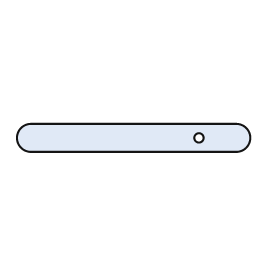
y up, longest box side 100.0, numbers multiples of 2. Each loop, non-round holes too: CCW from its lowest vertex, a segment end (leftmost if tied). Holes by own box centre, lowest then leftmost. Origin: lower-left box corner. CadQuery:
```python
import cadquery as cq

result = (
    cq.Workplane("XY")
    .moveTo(6.0, 0.0)
    .lineTo(94.0, 0.0)
    .threePointArc((100.0, 6.0), (94.0, 12.0))
    .lineTo(6.0, 12.0)
    .threePointArc((0.0, 6.0), (6.0, 0.0))
    .close()
    .moveTo(78.0, 6.0)
    .circle(2.0)
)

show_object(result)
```